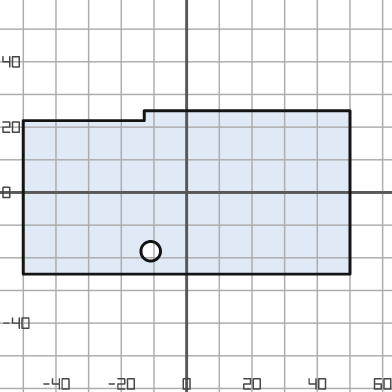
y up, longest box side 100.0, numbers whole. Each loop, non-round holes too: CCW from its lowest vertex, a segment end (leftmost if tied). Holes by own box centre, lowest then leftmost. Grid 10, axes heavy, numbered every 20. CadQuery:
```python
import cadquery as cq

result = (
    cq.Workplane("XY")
    .moveTo(-50.0, -25.0)
    .lineTo(50.0, -25.0)
    .lineTo(50.0, 25.0)
    .lineTo(-13.0, 25.0)
    .lineTo(-13.0, 22.0)
    .lineTo(-50.0, 22.0)
    .close()
    .moveTo(-11.0, -18.0)
    .circle(3.0)
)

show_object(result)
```